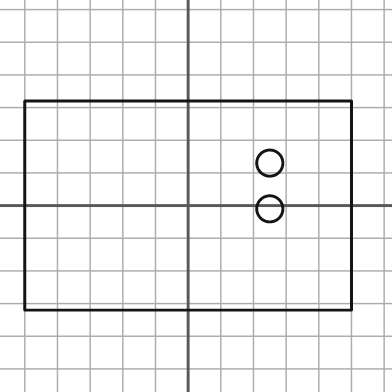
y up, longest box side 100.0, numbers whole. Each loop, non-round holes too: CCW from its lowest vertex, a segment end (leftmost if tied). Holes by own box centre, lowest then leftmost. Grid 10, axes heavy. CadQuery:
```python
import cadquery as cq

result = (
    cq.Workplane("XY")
    .moveTo(-50.0, -32.0)
    .lineTo(50.0, -32.0)
    .lineTo(50.0, 32.0)
    .lineTo(-50.0, 32.0)
    .close()
    .moveTo(25.0, -1.0)
    .circle(4.0)
    .moveTo(25.0, 13.0)
    .circle(4.0)
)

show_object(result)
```